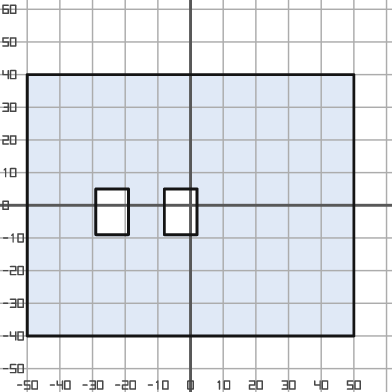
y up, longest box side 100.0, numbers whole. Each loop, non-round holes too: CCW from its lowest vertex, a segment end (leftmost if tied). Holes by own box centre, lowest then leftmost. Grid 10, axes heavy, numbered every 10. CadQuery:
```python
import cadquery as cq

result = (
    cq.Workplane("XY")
    .moveTo(-50.0, -40.0)
    .lineTo(50.0, -40.0)
    .lineTo(50.0, 40.0)
    .lineTo(-50.0, 40.0)
    .close()
    .moveTo(-29.0, -9.0)
    .lineTo(-19.0, -9.0)
    .lineTo(-19.0, 5.0)
    .lineTo(-29.0, 5.0)
    .close()
    .moveTo(-8.0, -9.0)
    .lineTo(2.0, -9.0)
    .lineTo(2.0, 5.0)
    .lineTo(-8.0, 5.0)
    .close()
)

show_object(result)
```